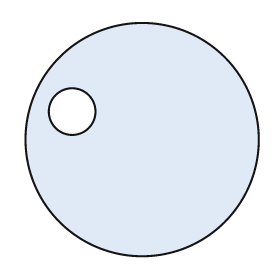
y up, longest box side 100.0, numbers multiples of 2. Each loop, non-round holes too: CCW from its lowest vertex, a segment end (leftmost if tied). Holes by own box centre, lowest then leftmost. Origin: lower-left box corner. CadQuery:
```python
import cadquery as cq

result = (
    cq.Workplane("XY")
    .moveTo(50.0, 50.0)
    .circle(50.0)
    .moveTo(20.0, 62.0)
    .circle(10.0)
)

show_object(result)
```